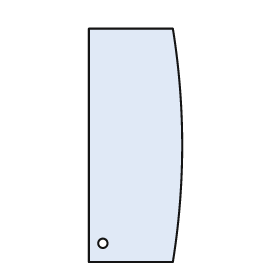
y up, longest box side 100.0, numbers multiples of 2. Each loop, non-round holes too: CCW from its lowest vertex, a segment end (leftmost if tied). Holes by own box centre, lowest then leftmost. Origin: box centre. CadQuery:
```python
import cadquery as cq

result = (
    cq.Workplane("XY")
    .moveTo(-20.0, -50.0)
    .lineTo(16.0, -50.0)
    .threePointArc((20.0, 0.0), (16.0, 50.0))
    .lineTo(-20.0, 50.0)
    .close()
    .moveTo(-14.0, -42.0)
    .circle(2.0)
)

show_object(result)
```